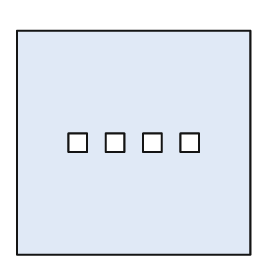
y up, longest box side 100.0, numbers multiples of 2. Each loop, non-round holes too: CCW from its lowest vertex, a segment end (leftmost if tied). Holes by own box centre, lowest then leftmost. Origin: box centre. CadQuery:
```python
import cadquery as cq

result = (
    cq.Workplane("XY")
    .moveTo(-50.0, -48.0)
    .lineTo(50.0, -48.0)
    .lineTo(50.0, 48.0)
    .lineTo(-50.0, 48.0)
    .close()
    .moveTo(-28.0, -4.0)
    .lineTo(-20.0, -4.0)
    .lineTo(-20.0, 4.0)
    .lineTo(-28.0, 4.0)
    .close()
    .moveTo(-12.0, -4.0)
    .lineTo(-4.0, -4.0)
    .lineTo(-4.0, 4.0)
    .lineTo(-12.0, 4.0)
    .close()
    .moveTo(4.0, -4.0)
    .lineTo(12.0, -4.0)
    .lineTo(12.0, 4.0)
    .lineTo(4.0, 4.0)
    .close()
    .moveTo(20.0, -4.0)
    .lineTo(28.0, -4.0)
    .lineTo(28.0, 4.0)
    .lineTo(20.0, 4.0)
    .close()
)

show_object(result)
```